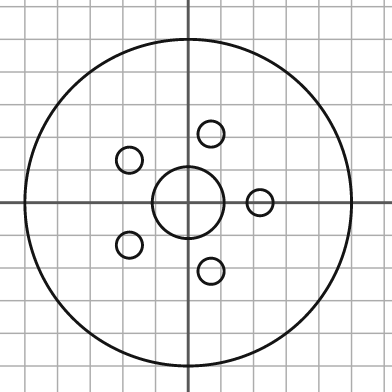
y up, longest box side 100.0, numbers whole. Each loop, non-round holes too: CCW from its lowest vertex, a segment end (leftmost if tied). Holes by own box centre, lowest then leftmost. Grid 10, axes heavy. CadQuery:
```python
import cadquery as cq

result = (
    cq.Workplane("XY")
    .moveTo(0.0, 0.0)
    .circle(50.0)
    .moveTo(7.0, -21.0)
    .circle(4.0)
    .moveTo(-18.0, -13.0)
    .circle(4.0)
    .moveTo(0.0, 0.0)
    .circle(11.0)
    .moveTo(22.0, 0.0)
    .circle(4.0)
    .moveTo(-18.0, 13.0)
    .circle(4.0)
    .moveTo(7.0, 21.0)
    .circle(4.0)
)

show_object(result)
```